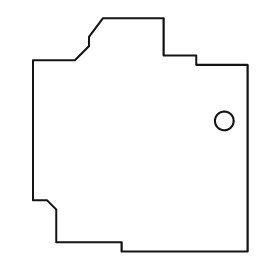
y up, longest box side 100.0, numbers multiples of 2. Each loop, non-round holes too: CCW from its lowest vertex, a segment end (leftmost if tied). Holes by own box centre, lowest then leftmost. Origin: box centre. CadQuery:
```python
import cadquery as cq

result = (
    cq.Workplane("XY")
    .moveTo(-8.0, -50.0)
    .lineTo(46.0, -50.0)
    .lineTo(46.0, 30.0)
    .lineTo(24.0, 30.0)
    .lineTo(24.0, 34.0)
    .lineTo(10.0, 34.0)
    .lineTo(10.0, 50.0)
    .lineTo(-16.0, 50.0)
    .lineTo(-22.0, 42.0)
    .lineTo(-22.0, 38.0)
    .lineTo(-28.0, 32.0)
    .lineTo(-46.0, 32.0)
    .lineTo(-46.0, -28.0)
    .lineTo(-40.0, -28.0)
    .lineTo(-36.0, -32.0)
    .lineTo(-36.0, -46.0)
    .lineTo(-8.0, -46.0)
    .close()
    .moveTo(36.0, 6.0)
    .circle(4.0)
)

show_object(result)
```